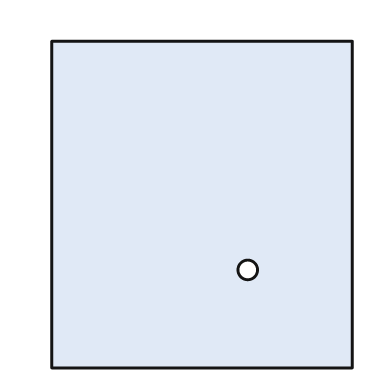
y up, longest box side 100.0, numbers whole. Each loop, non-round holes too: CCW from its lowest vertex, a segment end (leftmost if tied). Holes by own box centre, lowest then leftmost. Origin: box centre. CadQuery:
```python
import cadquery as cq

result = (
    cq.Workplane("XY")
    .moveTo(-46.0, -50.0)
    .lineTo(46.0, -50.0)
    .lineTo(46.0, 50.0)
    .lineTo(-46.0, 50.0)
    .close()
    .moveTo(14.0, -20.0)
    .circle(3.0)
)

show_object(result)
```